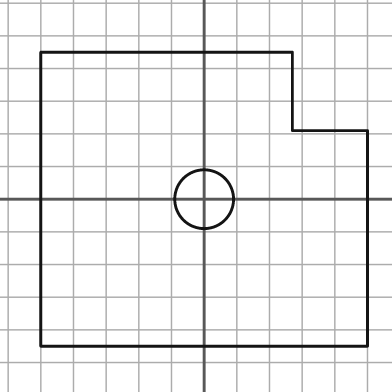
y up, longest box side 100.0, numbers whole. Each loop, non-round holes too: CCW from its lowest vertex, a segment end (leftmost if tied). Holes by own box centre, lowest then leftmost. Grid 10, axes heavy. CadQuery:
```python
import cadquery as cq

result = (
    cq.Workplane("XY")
    .moveTo(-50.0, -45.0)
    .lineTo(50.0, -45.0)
    .lineTo(50.0, 21.0)
    .lineTo(27.0, 21.0)
    .lineTo(27.0, 45.0)
    .lineTo(-50.0, 45.0)
    .close()
    .moveTo(0.0, 0.0)
    .circle(9.0)
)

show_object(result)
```